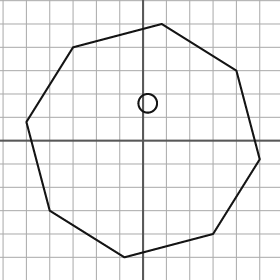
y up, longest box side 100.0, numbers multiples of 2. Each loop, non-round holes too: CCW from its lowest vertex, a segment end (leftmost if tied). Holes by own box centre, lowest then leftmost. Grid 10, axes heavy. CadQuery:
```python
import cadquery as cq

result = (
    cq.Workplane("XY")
    .moveTo(-8.0, -50.0)
    .lineTo(30.0, -40.0)
    .lineTo(50.0, -8.0)
    .lineTo(40.0, 30.0)
    .lineTo(8.0, 50.0)
    .lineTo(-30.0, 40.0)
    .lineTo(-50.0, 8.0)
    .lineTo(-40.0, -30.0)
    .close()
    .moveTo(2.0, 16.0)
    .circle(4.0)
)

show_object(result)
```